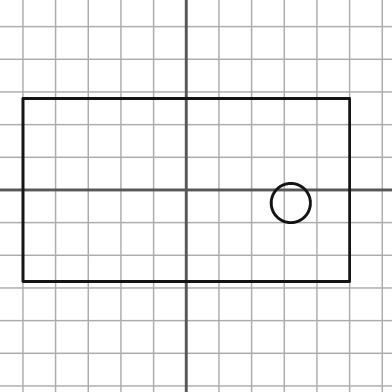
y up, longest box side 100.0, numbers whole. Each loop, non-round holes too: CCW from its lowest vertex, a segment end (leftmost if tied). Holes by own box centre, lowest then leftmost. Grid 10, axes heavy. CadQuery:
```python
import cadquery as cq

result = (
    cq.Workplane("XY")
    .moveTo(-50.0, -28.0)
    .lineTo(50.0, -28.0)
    .lineTo(50.0, 28.0)
    .lineTo(-50.0, 28.0)
    .close()
    .moveTo(32.0, -4.0)
    .circle(6.0)
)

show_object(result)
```